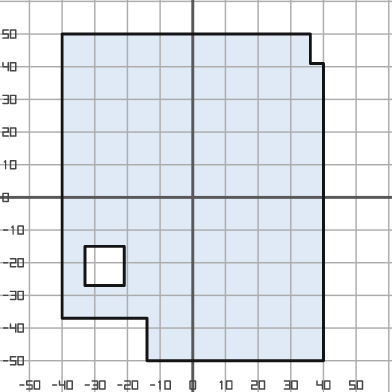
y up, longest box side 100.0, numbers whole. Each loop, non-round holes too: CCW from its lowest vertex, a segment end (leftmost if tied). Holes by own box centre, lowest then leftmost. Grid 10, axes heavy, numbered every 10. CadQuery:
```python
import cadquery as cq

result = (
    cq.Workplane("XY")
    .moveTo(-14.0, -50.0)
    .lineTo(40.0, -50.0)
    .lineTo(40.0, 41.0)
    .lineTo(36.0, 41.0)
    .lineTo(36.0, 50.0)
    .lineTo(-40.0, 50.0)
    .lineTo(-40.0, -37.0)
    .lineTo(-14.0, -37.0)
    .close()
    .moveTo(-33.0, -27.0)
    .lineTo(-21.0, -27.0)
    .lineTo(-21.0, -15.0)
    .lineTo(-33.0, -15.0)
    .close()
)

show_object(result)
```